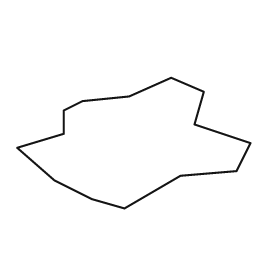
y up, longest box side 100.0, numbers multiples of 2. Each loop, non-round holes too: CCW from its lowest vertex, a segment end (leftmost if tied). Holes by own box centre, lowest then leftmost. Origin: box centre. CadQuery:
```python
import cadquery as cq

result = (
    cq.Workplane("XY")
    .moveTo(-4.0, -28.0)
    .lineTo(20.0, -14.0)
    .lineTo(44.0, -12.0)
    .lineTo(50.0, 0.0)
    .lineTo(26.0, 8.0)
    .lineTo(30.0, 22.0)
    .lineTo(16.0, 28.0)
    .lineTo(-2.0, 20.0)
    .lineTo(-22.0, 18.0)
    .lineTo(-30.0, 14.0)
    .lineTo(-30.0, 4.0)
    .lineTo(-50.0, -2.0)
    .lineTo(-34.0, -16.0)
    .lineTo(-18.0, -24.0)
    .close()
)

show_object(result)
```